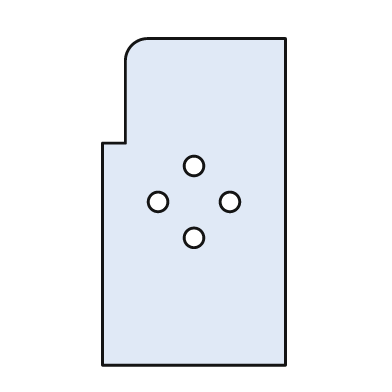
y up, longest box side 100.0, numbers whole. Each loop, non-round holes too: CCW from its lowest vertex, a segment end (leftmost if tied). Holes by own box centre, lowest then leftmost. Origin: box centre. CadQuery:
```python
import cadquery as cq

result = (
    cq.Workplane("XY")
    .moveTo(-28.0, -50.0)
    .lineTo(28.0, -50.0)
    .lineTo(28.0, 50.0)
    .lineTo(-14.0, 50.0)
    .threePointArc((-19.0, 48.0), (-21.0, 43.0))
    .lineTo(-21.0, 18.0)
    .lineTo(-28.0, 18.0)
    .close()
    .moveTo(0.0, -11.0)
    .circle(3.0)
    .moveTo(-11.0, 0.0)
    .circle(3.0)
    .moveTo(11.0, 0.0)
    .circle(3.0)
    .moveTo(0.0, 11.0)
    .circle(3.0)
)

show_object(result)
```